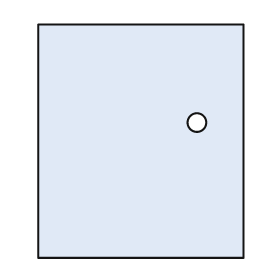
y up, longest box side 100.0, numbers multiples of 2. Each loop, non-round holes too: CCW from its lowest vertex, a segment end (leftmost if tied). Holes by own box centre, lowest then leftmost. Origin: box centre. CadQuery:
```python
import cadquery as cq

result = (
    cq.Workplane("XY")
    .moveTo(-44.0, -50.0)
    .lineTo(44.0, -50.0)
    .lineTo(44.0, 50.0)
    .lineTo(-44.0, 50.0)
    .close()
    .moveTo(24.0, 8.0)
    .circle(4.0)
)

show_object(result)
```